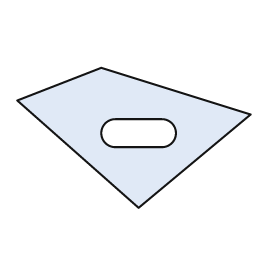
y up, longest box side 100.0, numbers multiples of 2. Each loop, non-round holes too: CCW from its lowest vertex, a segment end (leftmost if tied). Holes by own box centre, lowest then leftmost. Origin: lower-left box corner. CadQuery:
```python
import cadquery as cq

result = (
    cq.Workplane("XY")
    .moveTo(52.0, 0.0)
    .lineTo(100.0, 40.0)
    .lineTo(36.0, 60.0)
    .lineTo(0.0, 46.0)
    .close()
    .moveTo(42.0, 26.0)
    .lineTo(62.0, 26.0)
    .threePointArc((68.0, 32.0), (62.0, 38.0))
    .lineTo(42.0, 38.0)
    .threePointArc((36.0, 32.0), (42.0, 26.0))
    .close()
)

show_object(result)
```